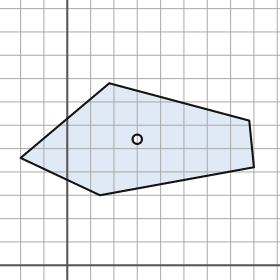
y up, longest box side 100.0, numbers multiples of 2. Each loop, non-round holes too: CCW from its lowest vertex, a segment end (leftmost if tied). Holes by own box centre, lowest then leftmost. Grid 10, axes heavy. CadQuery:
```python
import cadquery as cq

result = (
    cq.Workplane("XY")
    .moveTo(14.0, 30.0)
    .lineTo(80.0, 42.0)
    .lineTo(78.0, 62.0)
    .lineTo(18.0, 78.0)
    .lineTo(-20.0, 46.0)
    .close()
    .moveTo(30.0, 54.0)
    .circle(2.0)
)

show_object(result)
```